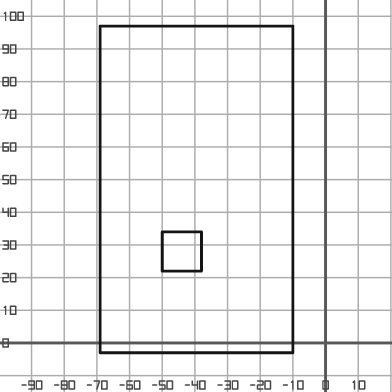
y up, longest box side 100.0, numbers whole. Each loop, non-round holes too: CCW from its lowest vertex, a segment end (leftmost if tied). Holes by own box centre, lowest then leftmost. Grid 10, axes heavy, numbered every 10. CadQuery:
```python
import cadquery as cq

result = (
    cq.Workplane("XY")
    .moveTo(-69.0, -3.0)
    .lineTo(-10.0, -3.0)
    .lineTo(-10.0, 97.0)
    .lineTo(-69.0, 97.0)
    .close()
    .moveTo(-50.0, 22.0)
    .lineTo(-38.0, 22.0)
    .lineTo(-38.0, 34.0)
    .lineTo(-50.0, 34.0)
    .close()
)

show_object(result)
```